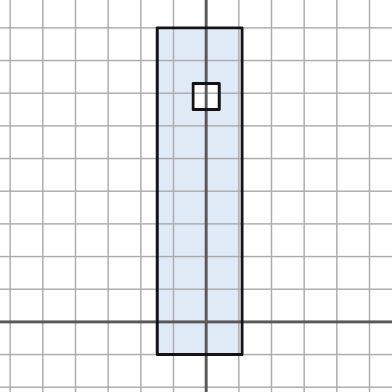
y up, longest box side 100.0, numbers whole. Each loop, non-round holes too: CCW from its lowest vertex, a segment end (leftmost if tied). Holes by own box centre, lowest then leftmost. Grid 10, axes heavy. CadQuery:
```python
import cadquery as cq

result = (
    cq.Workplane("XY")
    .moveTo(-15.0, -10.0)
    .lineTo(11.0, -10.0)
    .lineTo(11.0, 90.0)
    .lineTo(-15.0, 90.0)
    .close()
    .moveTo(-4.0, 65.0)
    .lineTo(4.0, 65.0)
    .lineTo(4.0, 73.0)
    .lineTo(-4.0, 73.0)
    .close()
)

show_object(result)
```